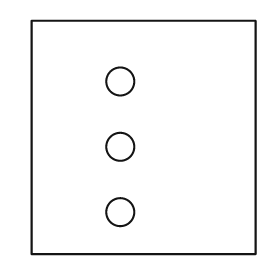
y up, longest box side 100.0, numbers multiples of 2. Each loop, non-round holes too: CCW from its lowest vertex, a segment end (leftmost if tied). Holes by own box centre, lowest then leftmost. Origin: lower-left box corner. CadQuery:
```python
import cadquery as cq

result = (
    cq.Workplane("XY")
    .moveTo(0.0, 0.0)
    .lineTo(96.0, 0.0)
    .lineTo(96.0, 100.0)
    .lineTo(0.0, 100.0)
    .close()
    .moveTo(38.0, 18.0)
    .circle(6.0)
    .moveTo(38.0, 46.0)
    .circle(6.0)
    .moveTo(38.0, 74.0)
    .circle(6.0)
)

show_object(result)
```